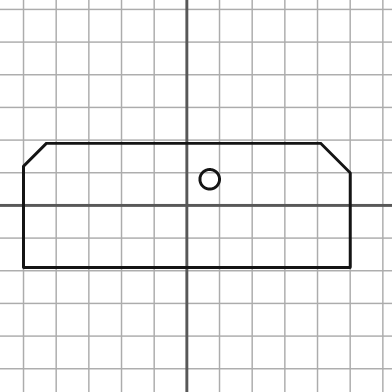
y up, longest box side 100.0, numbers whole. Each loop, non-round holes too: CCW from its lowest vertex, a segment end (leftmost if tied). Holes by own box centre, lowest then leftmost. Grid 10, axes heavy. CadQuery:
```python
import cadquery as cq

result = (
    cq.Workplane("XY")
    .moveTo(-50.0, -19.0)
    .lineTo(50.0, -19.0)
    .lineTo(50.0, 10.0)
    .lineTo(41.0, 19.0)
    .lineTo(-43.0, 19.0)
    .lineTo(-50.0, 12.0)
    .close()
    .moveTo(7.0, 8.0)
    .circle(3.0)
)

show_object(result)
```